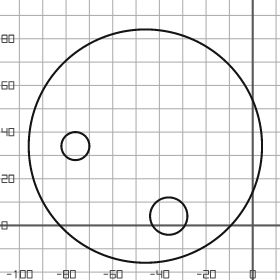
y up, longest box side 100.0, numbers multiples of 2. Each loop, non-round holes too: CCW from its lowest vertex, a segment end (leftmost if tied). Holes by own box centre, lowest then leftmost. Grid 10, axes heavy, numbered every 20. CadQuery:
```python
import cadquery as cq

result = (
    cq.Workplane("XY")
    .moveTo(-46.0, 34.0)
    .circle(50.0)
    .moveTo(-36.0, 4.0)
    .circle(8.0)
    .moveTo(-76.0, 34.0)
    .circle(6.0)
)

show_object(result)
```